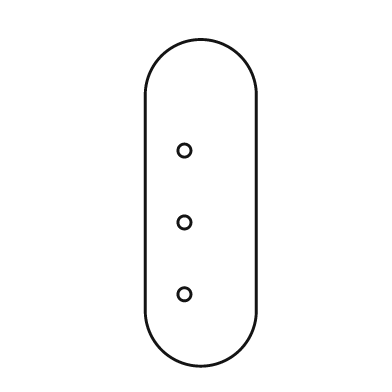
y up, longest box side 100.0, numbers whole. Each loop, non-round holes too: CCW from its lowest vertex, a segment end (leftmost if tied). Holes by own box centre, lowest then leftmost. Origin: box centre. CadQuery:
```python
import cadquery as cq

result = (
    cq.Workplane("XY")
    .moveTo(-17.0, -33.0)
    .threePointArc((0.0, -50.0), (17.0, -33.0))
    .lineTo(17.0, 33.0)
    .threePointArc((0.0, 50.0), (-17.0, 33.0))
    .close()
    .moveTo(-5.0, -28.0)
    .circle(2.0)
    .moveTo(-5.0, -6.0)
    .circle(2.0)
    .moveTo(-5.0, 16.0)
    .circle(2.0)
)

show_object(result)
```